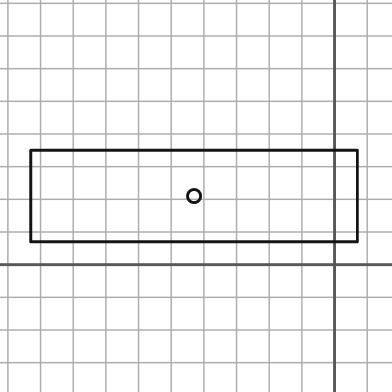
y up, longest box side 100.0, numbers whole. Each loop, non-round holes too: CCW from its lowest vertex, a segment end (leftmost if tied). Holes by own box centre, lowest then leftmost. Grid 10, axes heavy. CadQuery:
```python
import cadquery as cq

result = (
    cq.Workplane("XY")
    .moveTo(-93.0, 7.0)
    .lineTo(7.0, 7.0)
    .lineTo(7.0, 35.0)
    .lineTo(-93.0, 35.0)
    .close()
    .moveTo(-43.0, 21.0)
    .circle(2.0)
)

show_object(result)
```